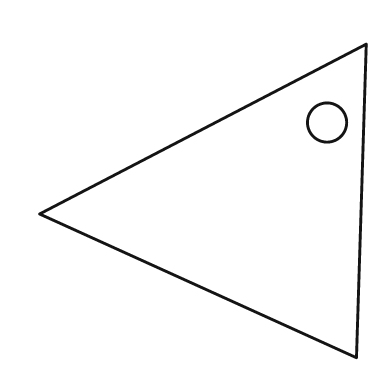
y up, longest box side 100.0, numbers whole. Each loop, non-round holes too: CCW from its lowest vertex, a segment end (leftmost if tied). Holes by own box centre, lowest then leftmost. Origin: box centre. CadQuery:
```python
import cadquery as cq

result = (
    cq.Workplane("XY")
    .moveTo(47.0, -48.0)
    .lineTo(50.0, 48.0)
    .lineTo(-50.0, -4.0)
    .close()
    .moveTo(38.0, 24.0)
    .circle(6.0)
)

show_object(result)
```